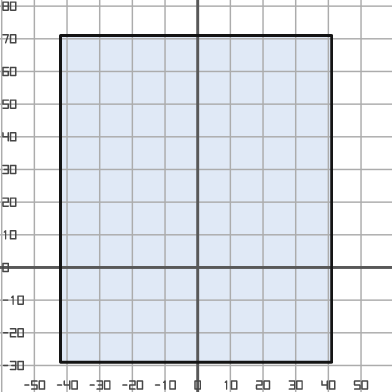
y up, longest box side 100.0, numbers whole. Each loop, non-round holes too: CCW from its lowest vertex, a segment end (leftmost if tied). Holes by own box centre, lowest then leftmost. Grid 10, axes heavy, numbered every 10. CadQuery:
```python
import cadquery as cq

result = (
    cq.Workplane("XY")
    .moveTo(-42.0, -29.0)
    .lineTo(41.0, -29.0)
    .lineTo(41.0, 71.0)
    .lineTo(-42.0, 71.0)
    .close()
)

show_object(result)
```